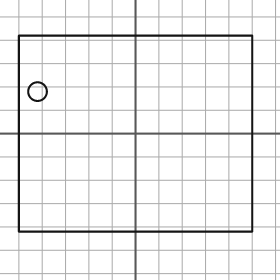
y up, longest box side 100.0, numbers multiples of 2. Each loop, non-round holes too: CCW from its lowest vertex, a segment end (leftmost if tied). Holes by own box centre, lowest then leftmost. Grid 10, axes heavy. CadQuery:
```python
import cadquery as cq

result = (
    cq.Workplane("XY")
    .moveTo(-50.0, -42.0)
    .lineTo(50.0, -42.0)
    .lineTo(50.0, 42.0)
    .lineTo(-50.0, 42.0)
    .close()
    .moveTo(-42.0, 18.0)
    .circle(4.0)
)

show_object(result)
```